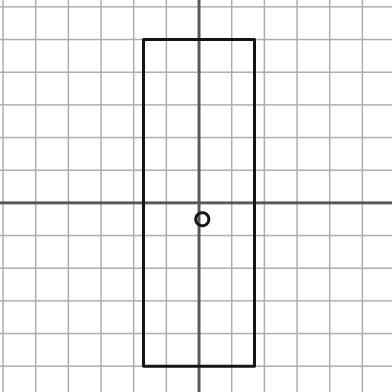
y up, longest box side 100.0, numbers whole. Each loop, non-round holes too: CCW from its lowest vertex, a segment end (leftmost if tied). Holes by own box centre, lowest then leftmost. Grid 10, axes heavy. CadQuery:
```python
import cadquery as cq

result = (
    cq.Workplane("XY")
    .moveTo(-17.0, -50.0)
    .lineTo(17.0, -50.0)
    .lineTo(17.0, 50.0)
    .lineTo(-17.0, 50.0)
    .close()
    .moveTo(1.0, -5.0)
    .circle(2.0)
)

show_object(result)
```